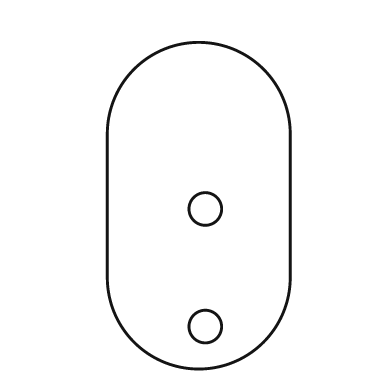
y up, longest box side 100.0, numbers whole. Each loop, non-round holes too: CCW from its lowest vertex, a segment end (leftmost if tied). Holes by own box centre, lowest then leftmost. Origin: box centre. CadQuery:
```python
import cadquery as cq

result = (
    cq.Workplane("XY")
    .moveTo(-28.0, -22.0)
    .threePointArc((0.0, -50.0), (28.0, -22.0))
    .lineTo(28.0, 22.0)
    .threePointArc((0.0, 50.0), (-28.0, 22.0))
    .close()
    .moveTo(2.0, -37.0)
    .circle(5.0)
    .moveTo(2.0, -1.0)
    .circle(5.0)
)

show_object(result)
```